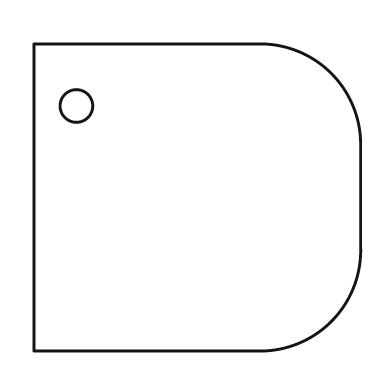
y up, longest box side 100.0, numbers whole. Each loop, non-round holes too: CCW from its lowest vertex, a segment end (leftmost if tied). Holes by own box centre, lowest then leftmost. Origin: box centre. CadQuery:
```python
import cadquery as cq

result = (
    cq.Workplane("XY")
    .moveTo(-50.0, -47.0)
    .lineTo(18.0, -47.0)
    .threePointArc((41.0, -38.0), (50.0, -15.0))
    .lineTo(50.0, 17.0)
    .threePointArc((41.0, 38.0), (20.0, 47.0))
    .lineTo(-50.0, 47.0)
    .close()
    .moveTo(-37.0, 28.0)
    .circle(5.0)
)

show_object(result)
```